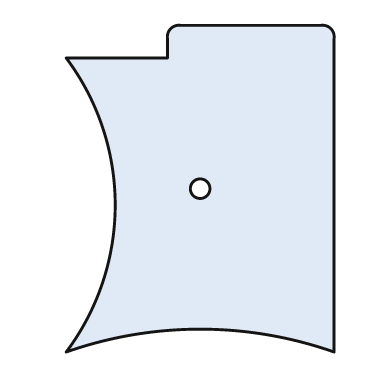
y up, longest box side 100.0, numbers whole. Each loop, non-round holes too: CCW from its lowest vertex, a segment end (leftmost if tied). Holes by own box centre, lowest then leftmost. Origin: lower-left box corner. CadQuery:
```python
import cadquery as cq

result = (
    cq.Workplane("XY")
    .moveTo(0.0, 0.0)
    .threePointArc((41.0, 7.0), (82.0, 0.0))
    .lineTo(82.0, 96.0)
    .threePointArc((81.0, 99.0), (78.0, 100.0))
    .lineTo(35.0, 100.0)
    .threePointArc((32.0, 99.0), (31.0, 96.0))
    .lineTo(31.0, 90.0)
    .lineTo(0.0, 90.0)
    .threePointArc((15.0, 45.0), (0.0, 0.0))
    .close()
    .moveTo(41.0, 50.0)
    .circle(3.0)
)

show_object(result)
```